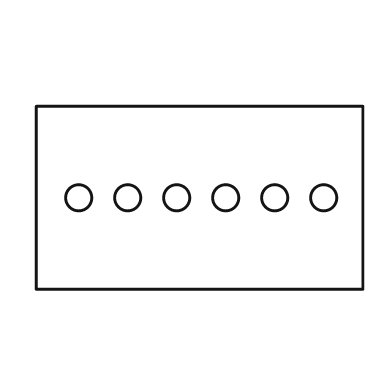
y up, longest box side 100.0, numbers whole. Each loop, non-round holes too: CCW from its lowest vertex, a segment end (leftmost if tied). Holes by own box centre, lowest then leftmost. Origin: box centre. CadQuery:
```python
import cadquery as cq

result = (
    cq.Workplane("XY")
    .moveTo(-50.0, -28.0)
    .lineTo(50.0, -28.0)
    .lineTo(50.0, 28.0)
    .lineTo(-50.0, 28.0)
    .close()
    .moveTo(-37.0, 0.0)
    .circle(4.0)
    .moveTo(-22.0, 0.0)
    .circle(4.0)
    .moveTo(-7.0, 0.0)
    .circle(4.0)
    .moveTo(8.0, 0.0)
    .circle(4.0)
    .moveTo(23.0, 0.0)
    .circle(4.0)
    .moveTo(38.0, 0.0)
    .circle(4.0)
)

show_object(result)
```